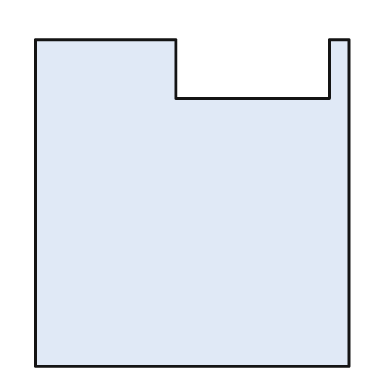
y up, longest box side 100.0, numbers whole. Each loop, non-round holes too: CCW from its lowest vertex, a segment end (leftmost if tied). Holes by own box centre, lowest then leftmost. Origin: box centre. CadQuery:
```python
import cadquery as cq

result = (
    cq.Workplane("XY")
    .moveTo(-48.0, -50.0)
    .lineTo(48.0, -50.0)
    .lineTo(48.0, 50.0)
    .lineTo(42.0, 50.0)
    .lineTo(42.0, 32.0)
    .lineTo(-5.0, 32.0)
    .lineTo(-5.0, 50.0)
    .lineTo(-48.0, 50.0)
    .close()
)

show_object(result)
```